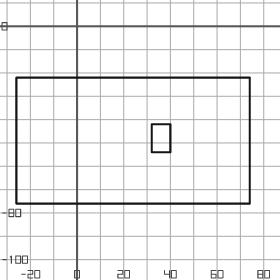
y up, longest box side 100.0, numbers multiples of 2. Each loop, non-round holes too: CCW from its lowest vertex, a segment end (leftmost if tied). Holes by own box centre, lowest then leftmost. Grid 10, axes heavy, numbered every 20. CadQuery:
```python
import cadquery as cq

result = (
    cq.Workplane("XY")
    .moveTo(-26.0, -76.0)
    .lineTo(74.0, -76.0)
    .lineTo(74.0, -22.0)
    .lineTo(-26.0, -22.0)
    .close()
    .moveTo(32.0, -54.0)
    .lineTo(40.0, -54.0)
    .lineTo(40.0, -42.0)
    .lineTo(32.0, -42.0)
    .close()
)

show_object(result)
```